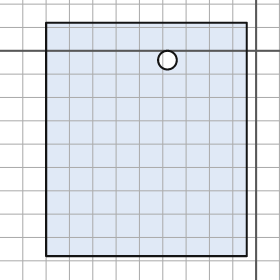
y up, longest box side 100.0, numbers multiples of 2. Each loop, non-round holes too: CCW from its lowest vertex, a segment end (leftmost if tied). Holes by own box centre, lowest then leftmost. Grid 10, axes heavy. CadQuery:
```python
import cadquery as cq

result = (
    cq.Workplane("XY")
    .moveTo(-90.0, -88.0)
    .lineTo(-4.0, -88.0)
    .lineTo(-4.0, 12.0)
    .lineTo(-90.0, 12.0)
    .close()
    .moveTo(-38.0, -4.0)
    .circle(4.0)
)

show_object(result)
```